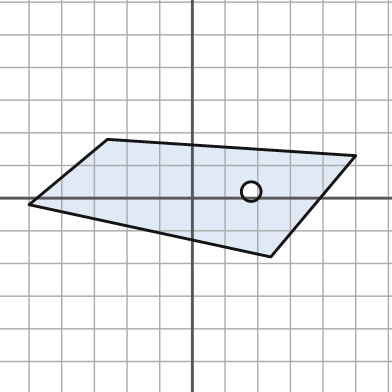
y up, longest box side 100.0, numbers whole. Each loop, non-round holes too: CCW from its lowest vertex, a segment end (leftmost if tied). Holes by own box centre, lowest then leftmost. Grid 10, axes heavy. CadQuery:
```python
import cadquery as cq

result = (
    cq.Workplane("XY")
    .moveTo(24.0, -18.0)
    .lineTo(50.0, 13.0)
    .lineTo(-26.0, 18.0)
    .lineTo(-50.0, -2.0)
    .close()
    .moveTo(18.0, 2.0)
    .circle(3.0)
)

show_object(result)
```